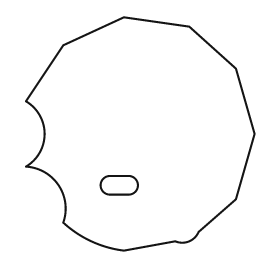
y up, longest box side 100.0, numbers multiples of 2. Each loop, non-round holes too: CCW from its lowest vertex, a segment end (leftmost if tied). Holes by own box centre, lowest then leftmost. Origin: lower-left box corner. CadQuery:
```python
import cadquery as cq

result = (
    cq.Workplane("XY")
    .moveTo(42.0, 0.0)
    .lineTo(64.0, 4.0)
    .threePointArc((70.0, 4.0), (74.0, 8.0))
    .lineTo(90.0, 22.0)
    .lineTo(98.0, 50.0)
    .lineTo(90.0, 78.0)
    .lineTo(70.0, 96.0)
    .lineTo(42.0, 100.0)
    .lineTo(16.0, 88.0)
    .lineTo(0.0, 64.0)
    .threePointArc((8.0, 50.0), (0.0, 36.0))
    .threePointArc((14.0, 28.0), (16.0, 12.0))
    .threePointArc((28.0, 4.0), (42.0, 0.0))
    .close()
    .moveTo(36.0, 24.0)
    .lineTo(44.0, 24.0)
    .threePointArc((48.0, 28.0), (44.0, 32.0))
    .lineTo(36.0, 32.0)
    .threePointArc((32.0, 28.0), (36.0, 24.0))
    .close()
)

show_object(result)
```